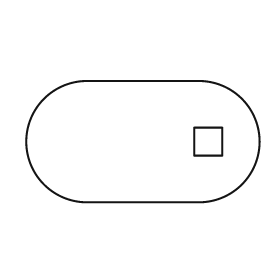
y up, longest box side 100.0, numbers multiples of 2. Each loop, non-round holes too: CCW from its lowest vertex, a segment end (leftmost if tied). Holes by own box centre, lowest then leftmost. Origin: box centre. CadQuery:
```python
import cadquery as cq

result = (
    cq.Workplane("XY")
    .moveTo(-24.0, -26.0)
    .lineTo(24.0, -26.0)
    .threePointArc((50.0, 0.0), (24.0, 26.0))
    .lineTo(-24.0, 26.0)
    .threePointArc((-50.0, 0.0), (-24.0, -26.0))
    .close()
    .moveTo(22.0, -6.0)
    .lineTo(34.0, -6.0)
    .lineTo(34.0, 6.0)
    .lineTo(22.0, 6.0)
    .close()
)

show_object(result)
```